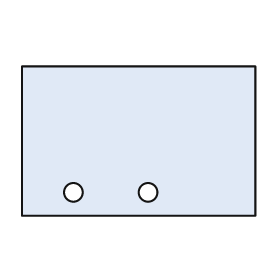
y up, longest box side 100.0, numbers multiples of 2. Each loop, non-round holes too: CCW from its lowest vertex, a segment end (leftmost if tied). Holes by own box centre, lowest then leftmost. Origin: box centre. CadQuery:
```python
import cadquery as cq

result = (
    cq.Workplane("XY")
    .moveTo(-50.0, -32.0)
    .lineTo(50.0, -32.0)
    .lineTo(50.0, 32.0)
    .lineTo(-50.0, 32.0)
    .close()
    .moveTo(-28.0, -22.0)
    .circle(4.0)
    .moveTo(4.0, -22.0)
    .circle(4.0)
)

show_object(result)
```